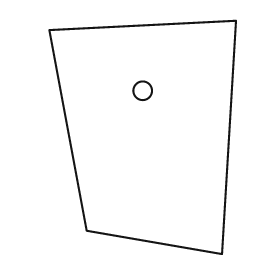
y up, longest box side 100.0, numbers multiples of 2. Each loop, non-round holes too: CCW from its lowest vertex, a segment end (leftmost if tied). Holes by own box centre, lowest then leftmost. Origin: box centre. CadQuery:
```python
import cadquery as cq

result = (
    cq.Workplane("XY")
    .moveTo(34.0, -50.0)
    .lineTo(40.0, 50.0)
    .lineTo(-40.0, 46.0)
    .lineTo(-24.0, -40.0)
    .close()
    .moveTo(0.0, 20.0)
    .circle(4.0)
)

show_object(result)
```